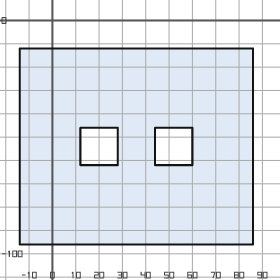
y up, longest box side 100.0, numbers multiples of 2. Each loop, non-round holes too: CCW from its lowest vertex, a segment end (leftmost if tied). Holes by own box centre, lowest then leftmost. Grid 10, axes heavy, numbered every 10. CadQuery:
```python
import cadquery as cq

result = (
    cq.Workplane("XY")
    .moveTo(-14.0, -96.0)
    .lineTo(86.0, -96.0)
    .lineTo(86.0, -12.0)
    .lineTo(-14.0, -12.0)
    .close()
    .moveTo(12.0, -62.0)
    .lineTo(28.0, -62.0)
    .lineTo(28.0, -46.0)
    .lineTo(12.0, -46.0)
    .close()
    .moveTo(44.0, -62.0)
    .lineTo(60.0, -62.0)
    .lineTo(60.0, -46.0)
    .lineTo(44.0, -46.0)
    .close()
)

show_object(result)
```